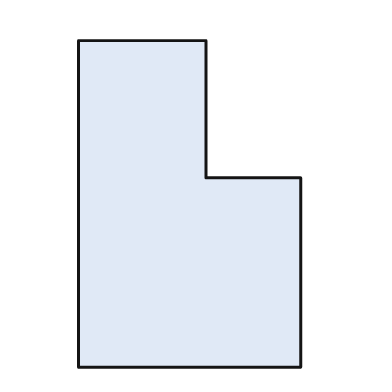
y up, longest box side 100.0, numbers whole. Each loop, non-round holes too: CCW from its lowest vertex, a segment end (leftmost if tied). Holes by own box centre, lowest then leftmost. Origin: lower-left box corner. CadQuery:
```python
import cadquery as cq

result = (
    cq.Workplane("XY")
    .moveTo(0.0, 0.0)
    .lineTo(68.0, 0.0)
    .lineTo(68.0, 58.0)
    .lineTo(39.0, 58.0)
    .lineTo(39.0, 100.0)
    .lineTo(0.0, 100.0)
    .close()
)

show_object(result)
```